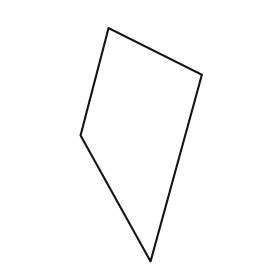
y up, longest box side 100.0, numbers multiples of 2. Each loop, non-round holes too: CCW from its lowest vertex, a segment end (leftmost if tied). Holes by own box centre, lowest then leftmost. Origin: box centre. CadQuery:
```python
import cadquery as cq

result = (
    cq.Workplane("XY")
    .moveTo(4.0, -50.0)
    .lineTo(26.0, 30.0)
    .lineTo(-14.0, 50.0)
    .lineTo(-26.0, 4.0)
    .close()
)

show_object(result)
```